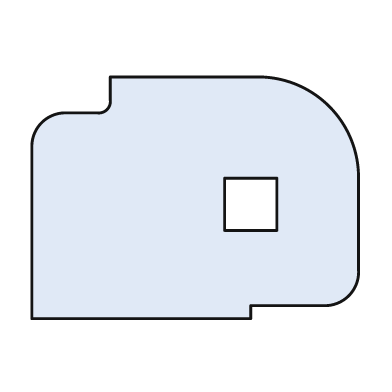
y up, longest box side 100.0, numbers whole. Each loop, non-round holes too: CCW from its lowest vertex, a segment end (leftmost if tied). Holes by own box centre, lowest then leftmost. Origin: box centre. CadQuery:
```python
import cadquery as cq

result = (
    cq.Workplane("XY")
    .moveTo(-50.0, -37.0)
    .lineTo(17.0, -37.0)
    .lineTo(17.0, -33.0)
    .lineTo(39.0, -33.0)
    .threePointArc((47.0, -30.0), (50.0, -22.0))
    .lineTo(50.0, 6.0)
    .threePointArc((41.0, 28.0), (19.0, 37.0))
    .lineTo(-26.0, 37.0)
    .lineTo(-26.0, 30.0)
    .threePointArc((-27.0, 27.0), (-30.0, 26.0))
    .lineTo(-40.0, 26.0)
    .threePointArc((-47.0, 23.0), (-50.0, 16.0))
    .close()
    .moveTo(9.0, -10.0)
    .lineTo(25.0, -10.0)
    .lineTo(25.0, 6.0)
    .lineTo(9.0, 6.0)
    .close()
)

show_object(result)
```